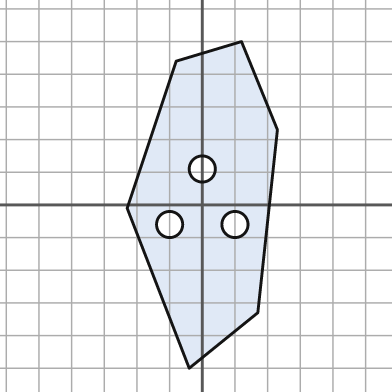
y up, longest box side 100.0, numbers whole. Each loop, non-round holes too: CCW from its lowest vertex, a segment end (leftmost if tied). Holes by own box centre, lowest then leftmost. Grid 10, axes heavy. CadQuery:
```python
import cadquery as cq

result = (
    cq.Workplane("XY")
    .moveTo(-4.0, -50.0)
    .lineTo(17.0, -33.0)
    .lineTo(23.0, 23.0)
    .lineTo(12.0, 50.0)
    .lineTo(-8.0, 44.0)
    .lineTo(-23.0, -1.0)
    .close()
    .moveTo(-10.0, -6.0)
    .circle(4.0)
    .moveTo(10.0, -6.0)
    .circle(4.0)
    .moveTo(0.0, 11.0)
    .circle(4.0)
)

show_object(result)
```